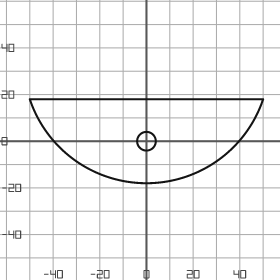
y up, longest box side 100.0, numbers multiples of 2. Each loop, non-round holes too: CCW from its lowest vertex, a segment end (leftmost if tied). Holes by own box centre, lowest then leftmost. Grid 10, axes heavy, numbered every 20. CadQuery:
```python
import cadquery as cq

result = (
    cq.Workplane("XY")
    .moveTo(-50.0, 18.0)
    .threePointArc((0.0, -18.0), (50.0, 18.0))
    .close()
    .moveTo(0.0, 0.0)
    .circle(4.0)
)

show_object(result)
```